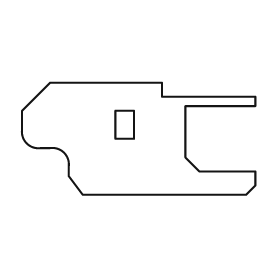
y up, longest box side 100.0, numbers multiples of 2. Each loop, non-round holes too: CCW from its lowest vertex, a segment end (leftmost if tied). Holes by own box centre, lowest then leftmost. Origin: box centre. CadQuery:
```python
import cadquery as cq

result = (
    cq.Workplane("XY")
    .moveTo(-24.0, -24.0)
    .lineTo(46.0, -24.0)
    .lineTo(50.0, -20.0)
    .lineTo(50.0, -14.0)
    .lineTo(26.0, -14.0)
    .lineTo(20.0, -8.0)
    .lineTo(20.0, 14.0)
    .lineTo(50.0, 14.0)
    .lineTo(50.0, 18.0)
    .lineTo(10.0, 18.0)
    .lineTo(10.0, 24.0)
    .lineTo(-38.0, 24.0)
    .lineTo(-50.0, 12.0)
    .lineTo(-50.0, 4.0)
    .threePointArc((-48.0, -2.0), (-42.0, -4.0))
    .lineTo(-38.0, -4.0)
    .threePointArc((-32.0, -6.0), (-30.0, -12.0))
    .lineTo(-30.0, -16.0)
    .close()
    .moveTo(-10.0, 0.0)
    .lineTo(-2.0, 0.0)
    .lineTo(-2.0, 12.0)
    .lineTo(-10.0, 12.0)
    .close()
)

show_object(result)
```